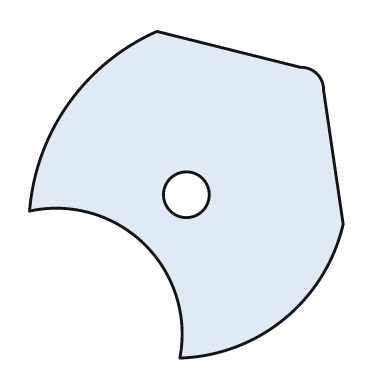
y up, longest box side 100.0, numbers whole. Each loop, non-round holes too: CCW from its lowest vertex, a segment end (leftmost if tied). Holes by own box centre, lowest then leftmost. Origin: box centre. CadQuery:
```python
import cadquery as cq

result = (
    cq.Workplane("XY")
    .moveTo(-2.0, -50.0)
    .threePointArc((30.0, -38.0), (48.0, -9.0))
    .lineTo(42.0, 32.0)
    .threePointArc((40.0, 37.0), (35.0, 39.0))
    .lineTo(-9.0, 50.0)
    .threePointArc((-36.0, 28.0), (-48.0, -5.0))
    .threePointArc((-13.0, -15.0), (-2.0, -50.0))
    .close()
    .moveTo(0.0, 0.0)
    .circle(7.0)
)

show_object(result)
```